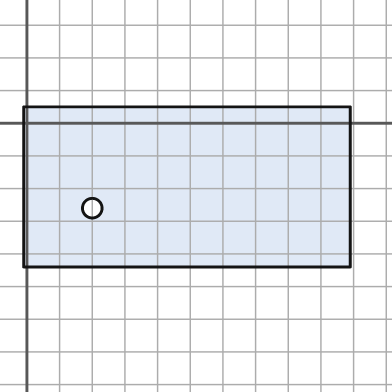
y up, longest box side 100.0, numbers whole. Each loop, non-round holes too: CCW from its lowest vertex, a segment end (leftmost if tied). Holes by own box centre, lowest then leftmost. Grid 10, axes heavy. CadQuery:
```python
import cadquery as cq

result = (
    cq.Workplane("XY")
    .moveTo(-1.0, -44.0)
    .lineTo(99.0, -44.0)
    .lineTo(99.0, 5.0)
    .lineTo(-1.0, 5.0)
    .close()
    .moveTo(20.0, -26.0)
    .circle(3.0)
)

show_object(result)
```